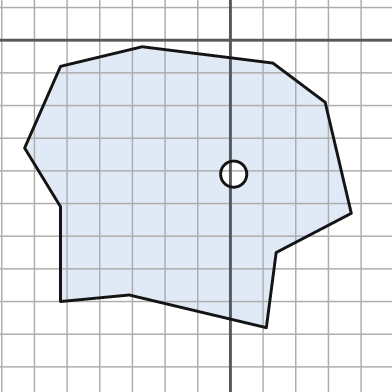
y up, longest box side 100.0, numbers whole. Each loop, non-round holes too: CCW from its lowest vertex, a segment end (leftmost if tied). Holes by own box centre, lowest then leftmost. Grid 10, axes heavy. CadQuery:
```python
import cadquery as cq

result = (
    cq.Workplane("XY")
    .moveTo(11.0, -88.0)
    .lineTo(14.0, -65.0)
    .lineTo(37.0, -53.0)
    .lineTo(29.0, -19.0)
    .lineTo(13.0, -7.0)
    .lineTo(-27.0, -2.0)
    .lineTo(-52.0, -8.0)
    .lineTo(-63.0, -33.0)
    .lineTo(-52.0, -51.0)
    .lineTo(-52.0, -80.0)
    .lineTo(-31.0, -78.0)
    .close()
    .moveTo(1.0, -41.0)
    .circle(4.0)
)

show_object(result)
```